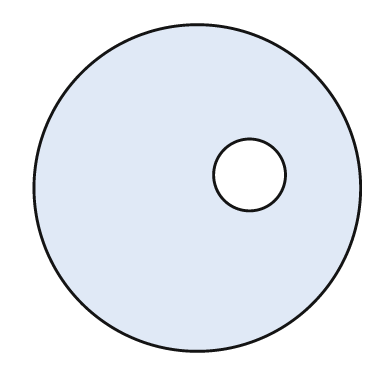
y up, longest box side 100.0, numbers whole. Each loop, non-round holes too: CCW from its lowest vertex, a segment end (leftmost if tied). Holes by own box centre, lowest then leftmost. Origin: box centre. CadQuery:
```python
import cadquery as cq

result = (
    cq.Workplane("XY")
    .moveTo(0.0, 0.0)
    .circle(50.0)
    .moveTo(16.0, 4.0)
    .circle(11.0)
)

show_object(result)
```